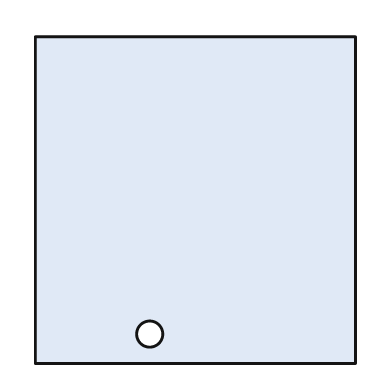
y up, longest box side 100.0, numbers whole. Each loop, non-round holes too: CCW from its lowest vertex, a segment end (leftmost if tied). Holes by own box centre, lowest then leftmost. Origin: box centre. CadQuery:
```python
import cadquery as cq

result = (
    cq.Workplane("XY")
    .moveTo(-49.0, -50.0)
    .lineTo(49.0, -50.0)
    .lineTo(49.0, 50.0)
    .lineTo(-49.0, 50.0)
    .close()
    .moveTo(-14.0, -41.0)
    .circle(4.0)
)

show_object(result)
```